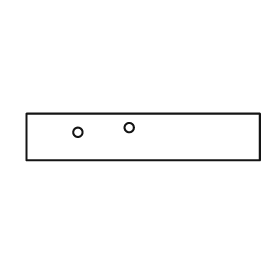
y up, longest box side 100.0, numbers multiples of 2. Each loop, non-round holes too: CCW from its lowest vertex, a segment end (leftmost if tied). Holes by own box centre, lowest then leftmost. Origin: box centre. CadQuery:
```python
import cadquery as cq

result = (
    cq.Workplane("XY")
    .moveTo(-50.0, -10.0)
    .lineTo(50.0, -10.0)
    .lineTo(50.0, 10.0)
    .lineTo(-50.0, 10.0)
    .close()
    .moveTo(-28.0, 2.0)
    .circle(2.0)
    .moveTo(-6.0, 4.0)
    .circle(2.0)
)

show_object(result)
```